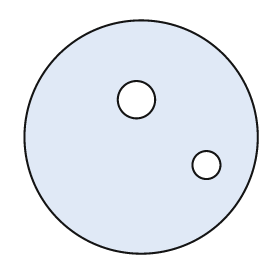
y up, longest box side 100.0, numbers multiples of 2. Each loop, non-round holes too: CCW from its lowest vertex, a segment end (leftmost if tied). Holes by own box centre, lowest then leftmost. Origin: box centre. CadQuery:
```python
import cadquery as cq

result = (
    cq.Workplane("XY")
    .moveTo(0.0, 0.0)
    .circle(50.0)
    .moveTo(28.0, -12.0)
    .circle(6.0)
    .moveTo(-2.0, 16.0)
    .circle(8.0)
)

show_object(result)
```